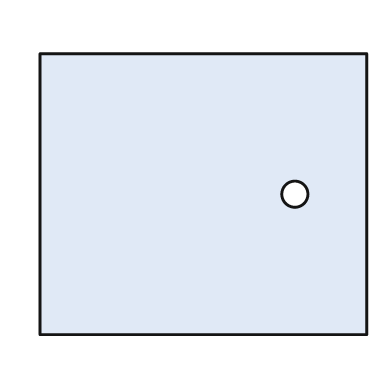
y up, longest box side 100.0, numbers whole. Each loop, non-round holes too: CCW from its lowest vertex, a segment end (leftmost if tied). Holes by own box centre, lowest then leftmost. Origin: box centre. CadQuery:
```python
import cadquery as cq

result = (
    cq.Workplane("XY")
    .moveTo(-50.0, -43.0)
    .lineTo(50.0, -43.0)
    .lineTo(50.0, 43.0)
    .lineTo(-50.0, 43.0)
    .close()
    .moveTo(28.0, 0.0)
    .circle(4.0)
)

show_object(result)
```